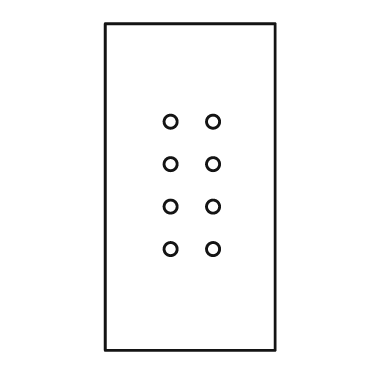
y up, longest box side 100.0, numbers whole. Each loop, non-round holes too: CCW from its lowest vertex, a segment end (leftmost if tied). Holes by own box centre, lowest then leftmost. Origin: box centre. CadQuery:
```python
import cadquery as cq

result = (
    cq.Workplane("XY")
    .moveTo(-26.0, -50.0)
    .lineTo(26.0, -50.0)
    .lineTo(26.0, 50.0)
    .lineTo(-26.0, 50.0)
    .close()
    .moveTo(-6.0, -19.0)
    .circle(2.0)
    .moveTo(7.0, -19.0)
    .circle(2.0)
    .moveTo(-6.0, -6.0)
    .circle(2.0)
    .moveTo(7.0, -6.0)
    .circle(2.0)
    .moveTo(-6.0, 7.0)
    .circle(2.0)
    .moveTo(7.0, 7.0)
    .circle(2.0)
    .moveTo(-6.0, 20.0)
    .circle(2.0)
    .moveTo(7.0, 20.0)
    .circle(2.0)
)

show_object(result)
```